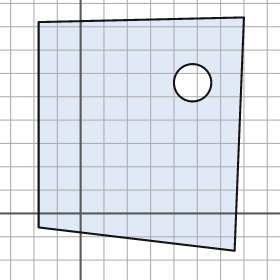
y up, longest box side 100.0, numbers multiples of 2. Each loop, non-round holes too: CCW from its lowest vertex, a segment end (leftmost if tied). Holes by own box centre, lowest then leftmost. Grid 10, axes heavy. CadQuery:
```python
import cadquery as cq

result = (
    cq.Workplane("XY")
    .moveTo(66.0, -16.0)
    .lineTo(70.0, 84.0)
    .lineTo(-18.0, 82.0)
    .lineTo(-18.0, -6.0)
    .close()
    .moveTo(48.0, 56.0)
    .circle(8.0)
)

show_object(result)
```